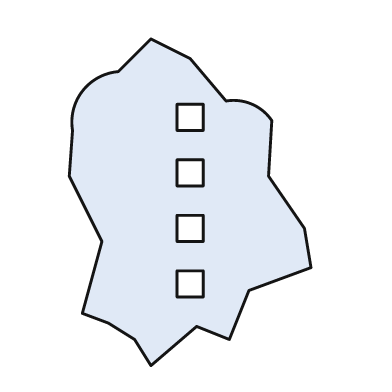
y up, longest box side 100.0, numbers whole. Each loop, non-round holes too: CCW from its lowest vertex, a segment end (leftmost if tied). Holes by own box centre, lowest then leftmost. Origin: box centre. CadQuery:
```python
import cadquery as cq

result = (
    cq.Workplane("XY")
    .moveTo(-12.0, -50.0)
    .lineTo(2.0, -38.0)
    .lineTo(12.0, -42.0)
    .lineTo(18.0, -27.0)
    .lineTo(37.0, -20.0)
    .lineTo(35.0, -8.0)
    .lineTo(24.0, 8.0)
    .lineTo(25.0, 25.0)
    .threePointArc((19.0, 30.0), (11.0, 31.0))
    .lineTo(0.0, 44.0)
    .lineTo(-12.0, 50.0)
    .lineTo(-22.0, 40.0)
    .threePointArc((-33.0, 34.0), (-36.0, 22.0))
    .lineTo(-37.0, 8.0)
    .lineTo(-27.0, -12.0)
    .lineTo(-33.0, -34.0)
    .lineTo(-25.0, -37.0)
    .lineTo(-17.0, -42.0)
    .close()
    .moveTo(-4.0, -29.0)
    .lineTo(4.0, -29.0)
    .lineTo(4.0, -21.0)
    .lineTo(-4.0, -21.0)
    .close()
    .moveTo(-4.0, -12.0)
    .lineTo(4.0, -12.0)
    .lineTo(4.0, -4.0)
    .lineTo(-4.0, -4.0)
    .close()
    .moveTo(-4.0, 5.0)
    .lineTo(4.0, 5.0)
    .lineTo(4.0, 13.0)
    .lineTo(-4.0, 13.0)
    .close()
    .moveTo(-4.0, 22.0)
    .lineTo(4.0, 22.0)
    .lineTo(4.0, 30.0)
    .lineTo(-4.0, 30.0)
    .close()
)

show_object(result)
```